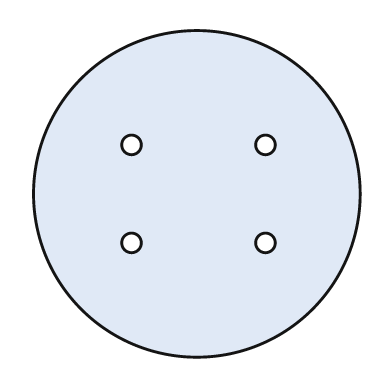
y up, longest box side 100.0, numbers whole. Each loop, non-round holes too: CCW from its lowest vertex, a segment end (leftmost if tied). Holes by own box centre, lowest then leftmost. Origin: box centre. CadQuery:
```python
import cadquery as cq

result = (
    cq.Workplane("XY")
    .moveTo(0.0, 0.0)
    .circle(50.0)
    .moveTo(-20.0, -15.0)
    .circle(3.0)
    .moveTo(21.0, -15.0)
    .circle(3.0)
    .moveTo(-20.0, 15.0)
    .circle(3.0)
    .moveTo(21.0, 15.0)
    .circle(3.0)
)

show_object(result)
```